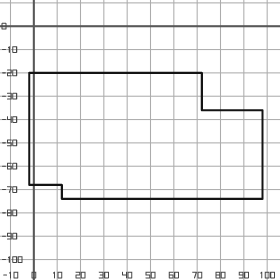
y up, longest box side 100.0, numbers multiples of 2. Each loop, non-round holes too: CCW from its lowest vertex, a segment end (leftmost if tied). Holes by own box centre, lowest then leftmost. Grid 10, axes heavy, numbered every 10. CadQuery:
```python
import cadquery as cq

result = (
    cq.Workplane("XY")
    .moveTo(12.0, -74.0)
    .lineTo(98.0, -74.0)
    .lineTo(98.0, -36.0)
    .lineTo(72.0, -36.0)
    .lineTo(72.0, -20.0)
    .lineTo(-2.0, -20.0)
    .lineTo(-2.0, -68.0)
    .lineTo(12.0, -68.0)
    .close()
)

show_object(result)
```